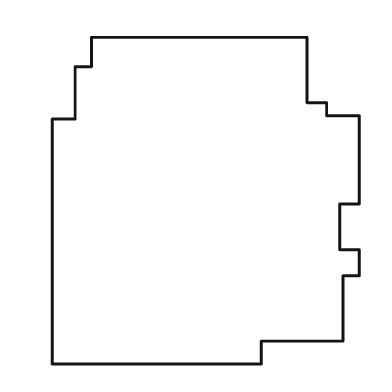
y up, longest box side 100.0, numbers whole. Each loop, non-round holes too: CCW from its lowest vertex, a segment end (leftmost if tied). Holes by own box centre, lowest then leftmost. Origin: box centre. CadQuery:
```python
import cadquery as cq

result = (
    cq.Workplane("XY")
    .moveTo(-47.0, -50.0)
    .lineTo(17.0, -50.0)
    .lineTo(17.0, -43.0)
    .lineTo(42.0, -43.0)
    .lineTo(42.0, -23.0)
    .lineTo(47.0, -23.0)
    .lineTo(47.0, -15.0)
    .lineTo(41.0, -15.0)
    .lineTo(41.0, -1.0)
    .lineTo(47.0, -1.0)
    .lineTo(47.0, 26.0)
    .lineTo(37.0, 26.0)
    .lineTo(37.0, 30.0)
    .lineTo(31.0, 30.0)
    .lineTo(31.0, 50.0)
    .lineTo(-35.0, 50.0)
    .lineTo(-35.0, 41.0)
    .lineTo(-40.0, 41.0)
    .lineTo(-40.0, 25.0)
    .lineTo(-47.0, 25.0)
    .close()
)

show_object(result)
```